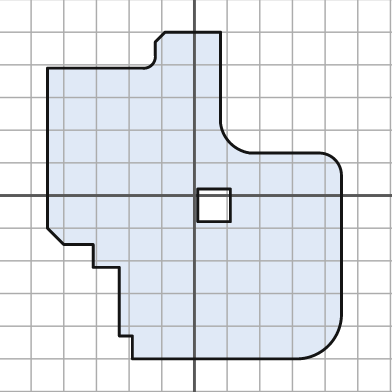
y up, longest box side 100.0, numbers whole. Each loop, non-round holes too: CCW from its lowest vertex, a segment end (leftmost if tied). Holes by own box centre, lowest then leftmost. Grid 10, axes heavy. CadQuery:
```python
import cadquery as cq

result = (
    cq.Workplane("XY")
    .moveTo(-19.0, -50.0)
    .lineTo(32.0, -50.0)
    .threePointArc((41.0, -46.0), (45.0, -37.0))
    .lineTo(45.0, 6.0)
    .threePointArc((43.0, 11.0), (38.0, 13.0))
    .lineTo(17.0, 13.0)
    .threePointArc((11.0, 16.0), (8.0, 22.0))
    .lineTo(8.0, 50.0)
    .lineTo(-9.0, 50.0)
    .lineTo(-12.0, 47.0)
    .lineTo(-12.0, 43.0)
    .threePointArc((-13.0, 40.0), (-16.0, 39.0))
    .lineTo(-45.0, 39.0)
    .lineTo(-45.0, -10.0)
    .lineTo(-40.0, -15.0)
    .lineTo(-31.0, -15.0)
    .lineTo(-31.0, -22.0)
    .lineTo(-23.0, -22.0)
    .lineTo(-23.0, -43.0)
    .lineTo(-19.0, -43.0)
    .close()
    .moveTo(1.0, -8.0)
    .lineTo(11.0, -8.0)
    .lineTo(11.0, 2.0)
    .lineTo(1.0, 2.0)
    .close()
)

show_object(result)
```